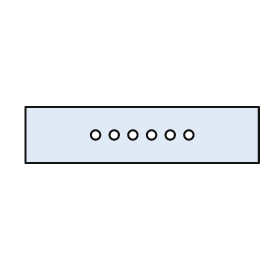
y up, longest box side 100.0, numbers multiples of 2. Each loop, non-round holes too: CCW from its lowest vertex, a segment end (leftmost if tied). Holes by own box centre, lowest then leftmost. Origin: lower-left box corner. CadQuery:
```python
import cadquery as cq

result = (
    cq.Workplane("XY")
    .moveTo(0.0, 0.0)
    .lineTo(100.0, 0.0)
    .lineTo(100.0, 24.0)
    .lineTo(0.0, 24.0)
    .close()
    .moveTo(30.0, 12.0)
    .circle(2.0)
    .moveTo(38.0, 12.0)
    .circle(2.0)
    .moveTo(46.0, 12.0)
    .circle(2.0)
    .moveTo(54.0, 12.0)
    .circle(2.0)
    .moveTo(62.0, 12.0)
    .circle(2.0)
    .moveTo(70.0, 12.0)
    .circle(2.0)
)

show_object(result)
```